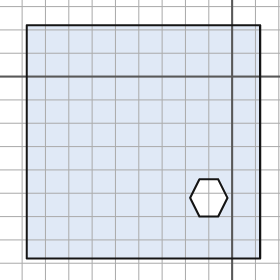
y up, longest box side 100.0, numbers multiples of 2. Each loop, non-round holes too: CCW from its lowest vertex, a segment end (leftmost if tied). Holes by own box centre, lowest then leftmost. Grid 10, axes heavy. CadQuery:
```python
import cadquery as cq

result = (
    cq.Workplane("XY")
    .moveTo(-88.0, -78.0)
    .lineTo(12.0, -78.0)
    .lineTo(12.0, 22.0)
    .lineTo(-88.0, 22.0)
    .close()
    .moveTo(-14.0, -60.0)
    .lineTo(-6.0, -60.0)
    .lineTo(-2.0, -52.0)
    .lineTo(-6.0, -44.0)
    .lineTo(-14.0, -44.0)
    .lineTo(-18.0, -52.0)
    .close()
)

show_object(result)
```